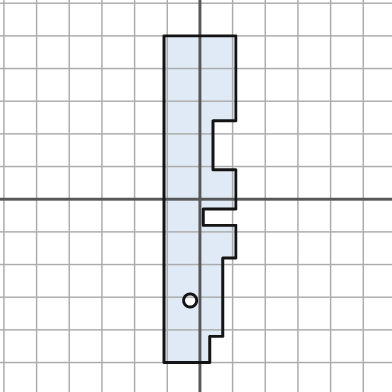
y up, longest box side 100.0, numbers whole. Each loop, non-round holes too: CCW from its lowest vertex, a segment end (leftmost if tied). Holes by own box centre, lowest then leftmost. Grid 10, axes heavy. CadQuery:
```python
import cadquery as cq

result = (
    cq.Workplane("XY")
    .moveTo(-11.0, -50.0)
    .lineTo(3.0, -50.0)
    .lineTo(3.0, -42.0)
    .lineTo(7.0, -42.0)
    .lineTo(7.0, -18.0)
    .lineTo(11.0, -18.0)
    .lineTo(11.0, -8.0)
    .lineTo(1.0, -8.0)
    .lineTo(1.0, -3.0)
    .lineTo(11.0, -3.0)
    .lineTo(11.0, 9.0)
    .lineTo(4.0, 9.0)
    .lineTo(4.0, 24.0)
    .lineTo(11.0, 24.0)
    .lineTo(11.0, 50.0)
    .lineTo(-11.0, 50.0)
    .close()
    .moveTo(-3.0, -31.0)
    .circle(2.0)
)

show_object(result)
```